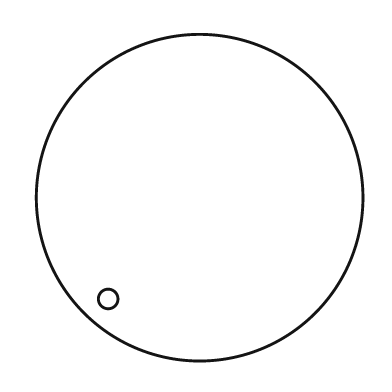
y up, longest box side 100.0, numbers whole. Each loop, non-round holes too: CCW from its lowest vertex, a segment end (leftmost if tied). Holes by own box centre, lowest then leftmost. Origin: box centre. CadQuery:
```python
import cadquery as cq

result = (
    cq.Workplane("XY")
    .moveTo(0.0, 0.0)
    .circle(50.0)
    .moveTo(-28.0, -31.0)
    .circle(3.0)
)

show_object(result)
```